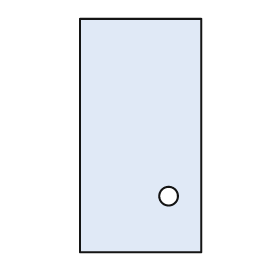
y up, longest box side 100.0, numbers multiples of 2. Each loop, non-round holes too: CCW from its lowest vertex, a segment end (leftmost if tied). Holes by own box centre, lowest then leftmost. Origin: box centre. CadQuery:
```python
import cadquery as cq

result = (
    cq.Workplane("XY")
    .moveTo(-26.0, -50.0)
    .lineTo(26.0, -50.0)
    .lineTo(26.0, 50.0)
    .lineTo(-26.0, 50.0)
    .close()
    .moveTo(12.0, -26.0)
    .circle(4.0)
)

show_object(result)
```